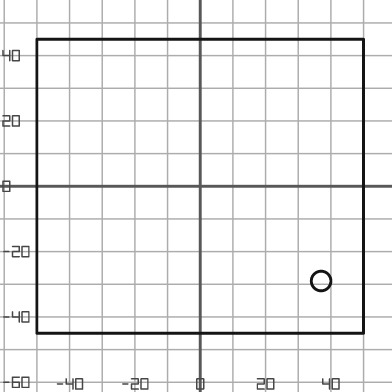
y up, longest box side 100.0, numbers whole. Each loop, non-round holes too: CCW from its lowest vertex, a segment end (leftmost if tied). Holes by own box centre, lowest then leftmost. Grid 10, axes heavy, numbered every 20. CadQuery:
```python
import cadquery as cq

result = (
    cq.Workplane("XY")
    .moveTo(-50.0, -45.0)
    .lineTo(50.0, -45.0)
    .lineTo(50.0, 45.0)
    .lineTo(-50.0, 45.0)
    .close()
    .moveTo(37.0, -29.0)
    .circle(3.0)
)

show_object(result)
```